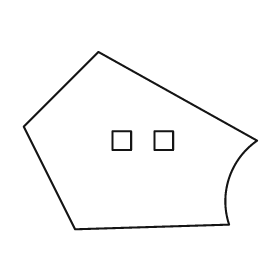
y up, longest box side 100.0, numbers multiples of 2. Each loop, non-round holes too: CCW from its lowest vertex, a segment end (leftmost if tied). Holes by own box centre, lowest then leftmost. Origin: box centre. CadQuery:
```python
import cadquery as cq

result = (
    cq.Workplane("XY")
    .moveTo(-28.0, -38.0)
    .lineTo(38.0, -36.0)
    .threePointArc((38.0, -16.0), (50.0, 0.0))
    .lineTo(-18.0, 38.0)
    .lineTo(-50.0, 6.0)
    .close()
    .moveTo(-12.0, -4.0)
    .lineTo(-4.0, -4.0)
    .lineTo(-4.0, 4.0)
    .lineTo(-12.0, 4.0)
    .close()
    .moveTo(6.0, -4.0)
    .lineTo(14.0, -4.0)
    .lineTo(14.0, 4.0)
    .lineTo(6.0, 4.0)
    .close()
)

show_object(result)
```